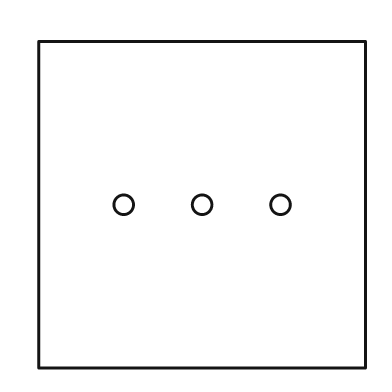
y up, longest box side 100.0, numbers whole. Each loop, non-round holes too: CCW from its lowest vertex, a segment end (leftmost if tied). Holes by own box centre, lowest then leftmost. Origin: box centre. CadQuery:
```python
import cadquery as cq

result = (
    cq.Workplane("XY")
    .moveTo(-50.0, -50.0)
    .lineTo(50.0, -50.0)
    .lineTo(50.0, 50.0)
    .lineTo(-50.0, 50.0)
    .close()
    .moveTo(-24.0, 0.0)
    .circle(3.0)
    .moveTo(0.0, 0.0)
    .circle(3.0)
    .moveTo(24.0, 0.0)
    .circle(3.0)
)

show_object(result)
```